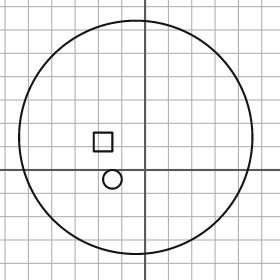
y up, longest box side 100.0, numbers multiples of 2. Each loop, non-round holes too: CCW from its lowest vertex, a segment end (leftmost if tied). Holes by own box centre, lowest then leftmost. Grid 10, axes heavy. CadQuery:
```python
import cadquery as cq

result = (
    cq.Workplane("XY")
    .moveTo(-4.0, 14.0)
    .circle(50.0)
    .moveTo(-14.0, -4.0)
    .circle(4.0)
    .moveTo(-22.0, 8.0)
    .lineTo(-14.0, 8.0)
    .lineTo(-14.0, 16.0)
    .lineTo(-22.0, 16.0)
    .close()
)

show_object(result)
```